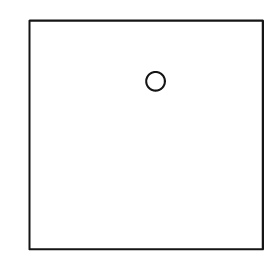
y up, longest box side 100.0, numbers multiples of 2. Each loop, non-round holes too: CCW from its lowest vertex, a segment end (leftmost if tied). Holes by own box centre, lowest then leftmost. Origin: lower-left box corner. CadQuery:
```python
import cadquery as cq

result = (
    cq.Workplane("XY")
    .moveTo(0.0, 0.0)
    .lineTo(100.0, 0.0)
    .lineTo(100.0, 98.0)
    .lineTo(0.0, 98.0)
    .close()
    .moveTo(54.0, 72.0)
    .circle(4.0)
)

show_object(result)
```